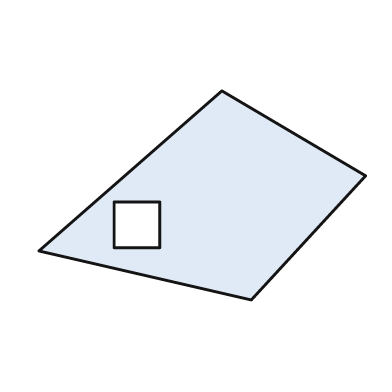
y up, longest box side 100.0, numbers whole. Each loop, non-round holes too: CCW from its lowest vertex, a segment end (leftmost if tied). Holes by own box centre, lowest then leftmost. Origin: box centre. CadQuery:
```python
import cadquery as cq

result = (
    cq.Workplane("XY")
    .moveTo(15.0, -32.0)
    .lineTo(50.0, 6.0)
    .lineTo(6.0, 32.0)
    .lineTo(-50.0, -17.0)
    .close()
    .moveTo(-27.0, -16.0)
    .lineTo(-13.0, -16.0)
    .lineTo(-13.0, -2.0)
    .lineTo(-27.0, -2.0)
    .close()
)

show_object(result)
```